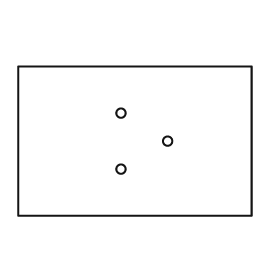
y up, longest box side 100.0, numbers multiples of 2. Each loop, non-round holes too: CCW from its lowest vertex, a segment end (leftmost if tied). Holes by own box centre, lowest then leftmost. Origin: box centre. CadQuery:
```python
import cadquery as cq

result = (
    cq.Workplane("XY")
    .moveTo(-50.0, -32.0)
    .lineTo(50.0, -32.0)
    .lineTo(50.0, 32.0)
    .lineTo(-50.0, 32.0)
    .close()
    .moveTo(-6.0, -12.0)
    .circle(2.0)
    .moveTo(14.0, 0.0)
    .circle(2.0)
    .moveTo(-6.0, 12.0)
    .circle(2.0)
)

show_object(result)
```